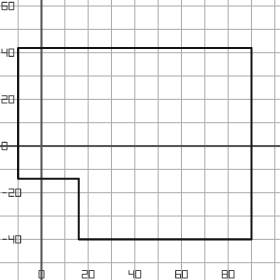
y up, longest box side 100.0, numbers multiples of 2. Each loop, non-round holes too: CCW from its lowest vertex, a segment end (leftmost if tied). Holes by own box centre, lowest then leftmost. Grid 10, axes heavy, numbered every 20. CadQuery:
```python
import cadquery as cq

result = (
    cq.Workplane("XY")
    .moveTo(16.0, -40.0)
    .lineTo(90.0, -40.0)
    .lineTo(90.0, 42.0)
    .lineTo(-10.0, 42.0)
    .lineTo(-10.0, -14.0)
    .lineTo(16.0, -14.0)
    .close()
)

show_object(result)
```